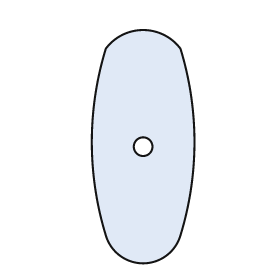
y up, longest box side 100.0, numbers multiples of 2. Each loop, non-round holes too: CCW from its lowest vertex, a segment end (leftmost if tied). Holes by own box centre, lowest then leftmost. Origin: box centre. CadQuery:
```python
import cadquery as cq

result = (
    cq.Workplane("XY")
    .moveTo(-16.0, -38.0)
    .threePointArc((0.0, -50.0), (16.0, -38.0))
    .threePointArc((22.0, 2.0), (16.0, 42.0))
    .threePointArc((0.0, 50.0), (-16.0, 42.0))
    .threePointArc((-22.0, 2.0), (-16.0, -38.0))
    .close()
    .moveTo(0.0, 0.0)
    .circle(4.0)
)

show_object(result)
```